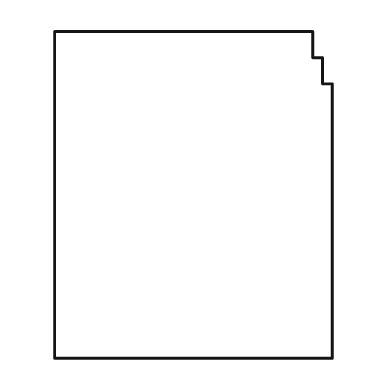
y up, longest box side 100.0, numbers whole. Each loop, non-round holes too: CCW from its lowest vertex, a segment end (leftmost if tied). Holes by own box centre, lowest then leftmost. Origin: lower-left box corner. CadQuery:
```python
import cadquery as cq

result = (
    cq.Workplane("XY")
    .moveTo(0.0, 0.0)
    .lineTo(85.0, 0.0)
    .lineTo(85.0, 84.0)
    .lineTo(82.0, 84.0)
    .lineTo(82.0, 92.0)
    .lineTo(79.0, 92.0)
    .lineTo(79.0, 100.0)
    .lineTo(0.0, 100.0)
    .close()
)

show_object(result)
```